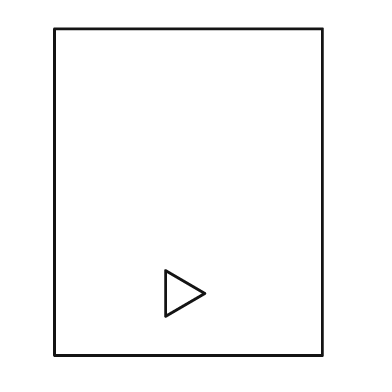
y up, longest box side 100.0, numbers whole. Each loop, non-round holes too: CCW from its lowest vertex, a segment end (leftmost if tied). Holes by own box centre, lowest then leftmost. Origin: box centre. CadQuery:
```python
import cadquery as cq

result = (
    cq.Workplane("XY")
    .moveTo(-41.0, -50.0)
    .lineTo(41.0, -50.0)
    .lineTo(41.0, 50.0)
    .lineTo(-41.0, 50.0)
    .close()
    .moveTo(-7.0, -38.0)
    .lineTo(5.0, -31.0)
    .lineTo(-7.0, -24.0)
    .close()
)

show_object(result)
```